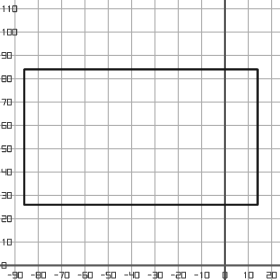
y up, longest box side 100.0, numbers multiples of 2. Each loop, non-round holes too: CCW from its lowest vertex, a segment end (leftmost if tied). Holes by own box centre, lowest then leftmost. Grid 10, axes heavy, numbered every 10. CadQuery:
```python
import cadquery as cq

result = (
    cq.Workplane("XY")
    .moveTo(-86.0, 26.0)
    .lineTo(14.0, 26.0)
    .lineTo(14.0, 84.0)
    .lineTo(-86.0, 84.0)
    .close()
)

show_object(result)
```